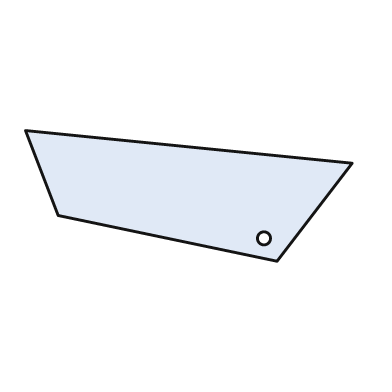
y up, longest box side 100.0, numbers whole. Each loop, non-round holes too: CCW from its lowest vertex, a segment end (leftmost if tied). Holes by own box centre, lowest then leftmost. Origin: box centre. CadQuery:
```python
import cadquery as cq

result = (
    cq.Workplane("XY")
    .moveTo(27.0, -20.0)
    .lineTo(50.0, 10.0)
    .lineTo(-50.0, 20.0)
    .lineTo(-40.0, -6.0)
    .close()
    .moveTo(23.0, -13.0)
    .circle(2.0)
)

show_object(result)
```